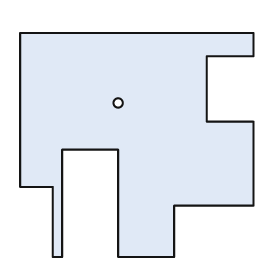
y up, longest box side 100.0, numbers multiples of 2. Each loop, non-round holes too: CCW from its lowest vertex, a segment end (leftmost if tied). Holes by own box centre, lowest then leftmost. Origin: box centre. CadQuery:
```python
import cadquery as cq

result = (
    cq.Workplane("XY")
    .moveTo(-36.0, -48.0)
    .lineTo(-32.0, -48.0)
    .lineTo(-32.0, -2.0)
    .lineTo(-8.0, -2.0)
    .lineTo(-8.0, -48.0)
    .lineTo(16.0, -48.0)
    .lineTo(16.0, -26.0)
    .lineTo(50.0, -26.0)
    .lineTo(50.0, 10.0)
    .lineTo(30.0, 10.0)
    .lineTo(30.0, 38.0)
    .lineTo(50.0, 38.0)
    .lineTo(50.0, 48.0)
    .lineTo(-50.0, 48.0)
    .lineTo(-50.0, -18.0)
    .lineTo(-36.0, -18.0)
    .close()
    .moveTo(-8.0, 18.0)
    .circle(2.0)
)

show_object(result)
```